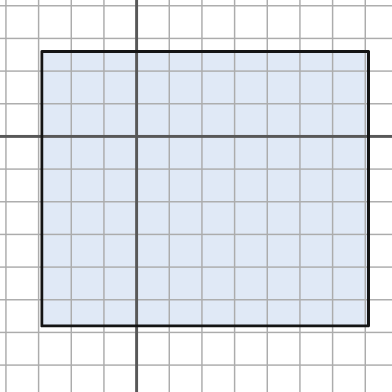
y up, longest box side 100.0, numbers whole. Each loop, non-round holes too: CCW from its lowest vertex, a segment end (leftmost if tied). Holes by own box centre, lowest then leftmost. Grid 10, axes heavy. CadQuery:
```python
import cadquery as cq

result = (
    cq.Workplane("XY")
    .moveTo(-29.0, -58.0)
    .lineTo(71.0, -58.0)
    .lineTo(71.0, 26.0)
    .lineTo(-29.0, 26.0)
    .close()
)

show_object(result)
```